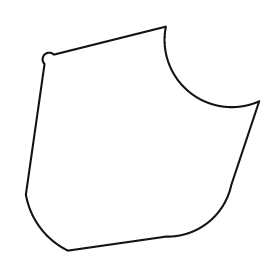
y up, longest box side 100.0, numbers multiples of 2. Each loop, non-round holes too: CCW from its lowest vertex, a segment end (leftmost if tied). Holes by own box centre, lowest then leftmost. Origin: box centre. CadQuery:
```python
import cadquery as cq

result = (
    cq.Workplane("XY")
    .moveTo(-32.0, -48.0)
    .lineTo(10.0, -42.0)
    .threePointArc((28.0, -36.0), (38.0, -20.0))
    .lineTo(50.0, 16.0)
    .threePointArc((20.0, 20.0), (10.0, 48.0))
    .lineTo(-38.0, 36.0)
    .threePointArc((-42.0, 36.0), (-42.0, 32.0))
    .lineTo(-50.0, -24.0)
    .threePointArc((-44.0, -38.0), (-32.0, -48.0))
    .close()
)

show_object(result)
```